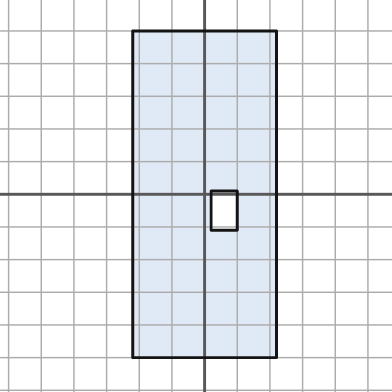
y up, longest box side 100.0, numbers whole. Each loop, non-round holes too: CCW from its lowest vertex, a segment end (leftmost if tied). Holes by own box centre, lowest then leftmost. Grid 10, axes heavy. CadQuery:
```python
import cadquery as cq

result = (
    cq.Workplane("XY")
    .moveTo(-22.0, -50.0)
    .lineTo(22.0, -50.0)
    .lineTo(22.0, 50.0)
    .lineTo(-22.0, 50.0)
    .close()
    .moveTo(2.0, -11.0)
    .lineTo(10.0, -11.0)
    .lineTo(10.0, 1.0)
    .lineTo(2.0, 1.0)
    .close()
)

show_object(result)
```